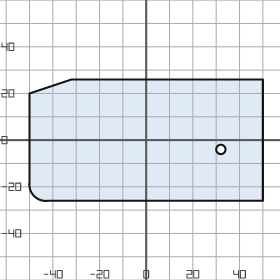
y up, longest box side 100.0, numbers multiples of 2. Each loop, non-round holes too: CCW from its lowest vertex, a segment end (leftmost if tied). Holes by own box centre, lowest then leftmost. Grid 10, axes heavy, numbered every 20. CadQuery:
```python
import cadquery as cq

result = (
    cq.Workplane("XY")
    .moveTo(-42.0, -26.0)
    .lineTo(50.0, -26.0)
    .lineTo(50.0, 26.0)
    .lineTo(-32.0, 26.0)
    .lineTo(-50.0, 20.0)
    .lineTo(-50.0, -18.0)
    .threePointArc((-48.0, -24.0), (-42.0, -26.0))
    .close()
    .moveTo(32.0, -4.0)
    .circle(2.0)
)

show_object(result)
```